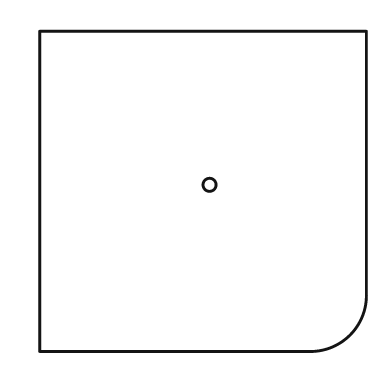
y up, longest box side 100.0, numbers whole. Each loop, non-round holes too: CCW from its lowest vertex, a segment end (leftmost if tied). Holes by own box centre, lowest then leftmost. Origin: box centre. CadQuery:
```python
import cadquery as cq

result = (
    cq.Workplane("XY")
    .moveTo(-50.0, -49.0)
    .lineTo(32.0, -49.0)
    .threePointArc((45.0, -44.0), (50.0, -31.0))
    .lineTo(50.0, 49.0)
    .lineTo(-50.0, 49.0)
    .close()
    .moveTo(2.0, 2.0)
    .circle(2.0)
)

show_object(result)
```